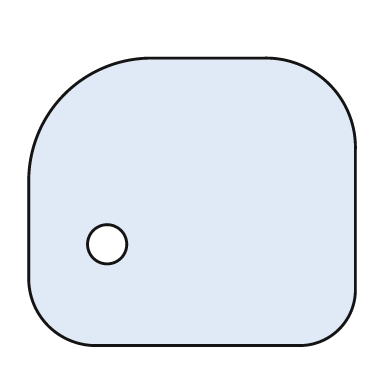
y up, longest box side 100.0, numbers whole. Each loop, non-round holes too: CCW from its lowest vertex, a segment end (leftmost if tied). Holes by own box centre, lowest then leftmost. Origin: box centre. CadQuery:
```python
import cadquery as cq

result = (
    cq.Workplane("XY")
    .moveTo(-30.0, -44.0)
    .lineTo(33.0, -44.0)
    .threePointArc((45.0, -39.0), (50.0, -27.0))
    .lineTo(50.0, 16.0)
    .threePointArc((42.0, 36.0), (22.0, 44.0))
    .lineTo(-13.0, 44.0)
    .threePointArc((-39.0, 33.0), (-50.0, 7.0))
    .lineTo(-50.0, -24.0)
    .threePointArc((-44.0, -38.0), (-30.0, -44.0))
    .close()
    .moveTo(-26.0, -13.0)
    .circle(6.0)
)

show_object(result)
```